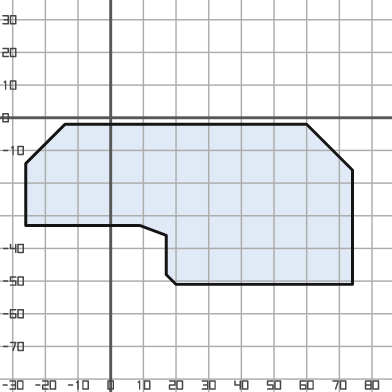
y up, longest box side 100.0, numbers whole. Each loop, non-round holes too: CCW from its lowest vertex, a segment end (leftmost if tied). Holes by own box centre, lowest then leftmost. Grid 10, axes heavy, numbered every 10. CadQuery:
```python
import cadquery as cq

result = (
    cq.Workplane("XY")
    .moveTo(20.0, -51.0)
    .lineTo(74.0, -51.0)
    .lineTo(74.0, -16.0)
    .lineTo(60.0, -2.0)
    .lineTo(-14.0, -2.0)
    .lineTo(-26.0, -14.0)
    .lineTo(-26.0, -33.0)
    .lineTo(9.0, -33.0)
    .lineTo(17.0, -36.0)
    .lineTo(17.0, -48.0)
    .close()
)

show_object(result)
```